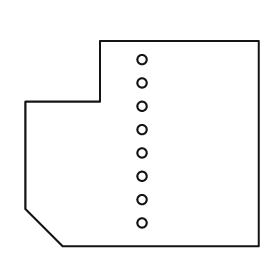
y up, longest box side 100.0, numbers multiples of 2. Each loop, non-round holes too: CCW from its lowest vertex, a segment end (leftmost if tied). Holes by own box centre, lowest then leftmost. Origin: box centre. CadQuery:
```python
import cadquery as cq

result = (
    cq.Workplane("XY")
    .moveTo(-34.0, -44.0)
    .lineTo(50.0, -44.0)
    .lineTo(50.0, 44.0)
    .lineTo(-18.0, 44.0)
    .lineTo(-18.0, 18.0)
    .lineTo(-50.0, 18.0)
    .lineTo(-50.0, -28.0)
    .close()
    .moveTo(0.0, -34.0)
    .circle(2.0)
    .moveTo(0.0, -24.0)
    .circle(2.0)
    .moveTo(0.0, -14.0)
    .circle(2.0)
    .moveTo(0.0, -4.0)
    .circle(2.0)
    .moveTo(0.0, 6.0)
    .circle(2.0)
    .moveTo(0.0, 16.0)
    .circle(2.0)
    .moveTo(0.0, 26.0)
    .circle(2.0)
    .moveTo(0.0, 36.0)
    .circle(2.0)
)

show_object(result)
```